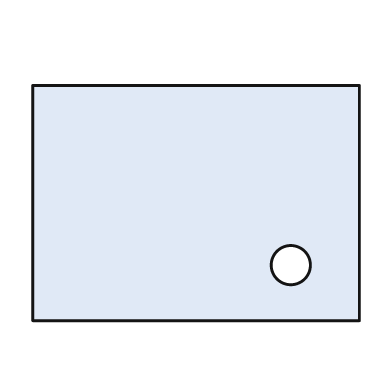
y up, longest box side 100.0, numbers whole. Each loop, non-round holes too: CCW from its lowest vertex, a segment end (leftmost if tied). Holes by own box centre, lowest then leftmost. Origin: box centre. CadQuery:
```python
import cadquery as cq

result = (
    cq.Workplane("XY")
    .moveTo(-50.0, -36.0)
    .lineTo(50.0, -36.0)
    .lineTo(50.0, 36.0)
    .lineTo(-50.0, 36.0)
    .close()
    .moveTo(29.0, -19.0)
    .circle(6.0)
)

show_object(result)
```